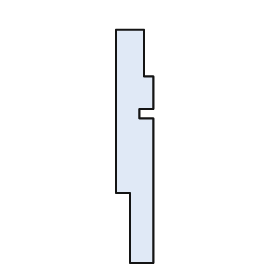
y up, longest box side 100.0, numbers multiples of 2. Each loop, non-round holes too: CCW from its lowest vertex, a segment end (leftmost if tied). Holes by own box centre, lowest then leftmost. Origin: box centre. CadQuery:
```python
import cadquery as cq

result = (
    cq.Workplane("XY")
    .moveTo(-2.0, -50.0)
    .lineTo(8.0, -50.0)
    .lineTo(8.0, 12.0)
    .lineTo(2.0, 12.0)
    .lineTo(2.0, 16.0)
    .lineTo(8.0, 16.0)
    .lineTo(8.0, 30.0)
    .lineTo(4.0, 30.0)
    .lineTo(4.0, 50.0)
    .lineTo(-8.0, 50.0)
    .lineTo(-8.0, -20.0)
    .lineTo(-2.0, -20.0)
    .close()
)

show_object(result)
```